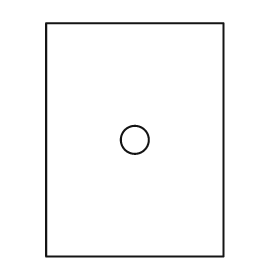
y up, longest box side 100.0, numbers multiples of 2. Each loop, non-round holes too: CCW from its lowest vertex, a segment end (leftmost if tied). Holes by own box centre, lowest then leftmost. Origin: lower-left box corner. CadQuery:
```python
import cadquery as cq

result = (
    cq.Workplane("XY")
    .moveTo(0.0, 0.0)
    .lineTo(76.0, 0.0)
    .lineTo(76.0, 100.0)
    .lineTo(0.0, 100.0)
    .close()
    .moveTo(38.0, 50.0)
    .circle(6.0)
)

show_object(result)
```